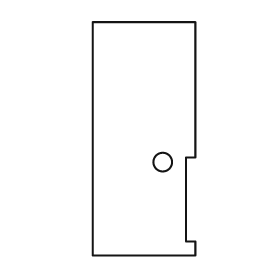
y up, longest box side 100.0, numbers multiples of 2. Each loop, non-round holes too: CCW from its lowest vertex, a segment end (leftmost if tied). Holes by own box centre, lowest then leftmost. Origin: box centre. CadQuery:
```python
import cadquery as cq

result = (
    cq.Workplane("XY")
    .moveTo(-22.0, -50.0)
    .lineTo(22.0, -50.0)
    .lineTo(22.0, -44.0)
    .lineTo(18.0, -44.0)
    .lineTo(18.0, -8.0)
    .lineTo(22.0, -8.0)
    .lineTo(22.0, 50.0)
    .lineTo(-22.0, 50.0)
    .close()
    .moveTo(8.0, -10.0)
    .circle(4.0)
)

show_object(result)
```